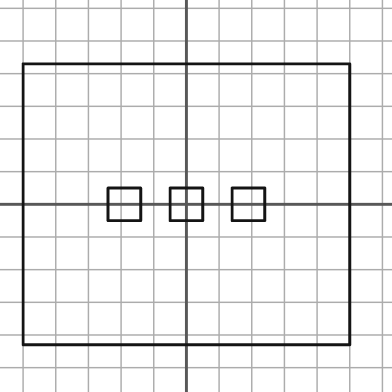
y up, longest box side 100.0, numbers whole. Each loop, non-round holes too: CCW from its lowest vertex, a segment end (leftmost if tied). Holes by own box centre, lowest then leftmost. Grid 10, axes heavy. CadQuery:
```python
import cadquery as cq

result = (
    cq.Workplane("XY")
    .moveTo(-50.0, -43.0)
    .lineTo(50.0, -43.0)
    .lineTo(50.0, 43.0)
    .lineTo(-50.0, 43.0)
    .close()
    .moveTo(-24.0, -5.0)
    .lineTo(-14.0, -5.0)
    .lineTo(-14.0, 5.0)
    .lineTo(-24.0, 5.0)
    .close()
    .moveTo(-5.0, -5.0)
    .lineTo(5.0, -5.0)
    .lineTo(5.0, 5.0)
    .lineTo(-5.0, 5.0)
    .close()
    .moveTo(14.0, -5.0)
    .lineTo(24.0, -5.0)
    .lineTo(24.0, 5.0)
    .lineTo(14.0, 5.0)
    .close()
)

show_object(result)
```